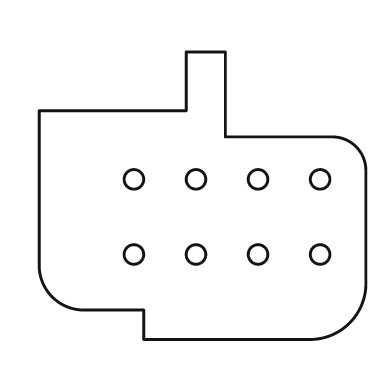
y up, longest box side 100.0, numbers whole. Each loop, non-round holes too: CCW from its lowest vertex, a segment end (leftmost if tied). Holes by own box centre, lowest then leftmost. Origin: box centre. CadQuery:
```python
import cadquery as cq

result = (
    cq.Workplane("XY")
    .moveTo(-18.0, -44.0)
    .lineTo(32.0, -44.0)
    .threePointArc((45.0, -39.0), (50.0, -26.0))
    .lineTo(50.0, 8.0)
    .threePointArc((47.0, 15.0), (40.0, 18.0))
    .lineTo(7.0, 18.0)
    .lineTo(7.0, 44.0)
    .lineTo(-5.0, 44.0)
    .lineTo(-5.0, 26.0)
    .lineTo(-50.0, 26.0)
    .lineTo(-50.0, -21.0)
    .threePointArc((-46.0, -31.0), (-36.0, -35.0))
    .lineTo(-18.0, -35.0)
    .close()
    .moveTo(-21.0, -18.0)
    .circle(3.0)
    .moveTo(-2.0, -18.0)
    .circle(3.0)
    .moveTo(17.0, -18.0)
    .circle(3.0)
    .moveTo(36.0, -18.0)
    .circle(3.0)
    .moveTo(-21.0, 5.0)
    .circle(3.0)
    .moveTo(-2.0, 5.0)
    .circle(3.0)
    .moveTo(17.0, 5.0)
    .circle(3.0)
    .moveTo(36.0, 5.0)
    .circle(3.0)
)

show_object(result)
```